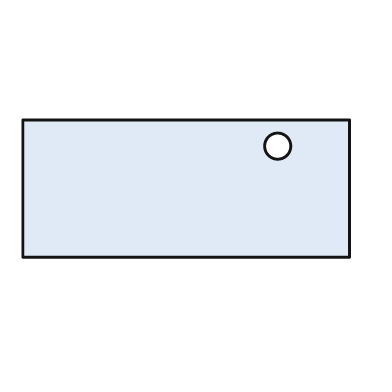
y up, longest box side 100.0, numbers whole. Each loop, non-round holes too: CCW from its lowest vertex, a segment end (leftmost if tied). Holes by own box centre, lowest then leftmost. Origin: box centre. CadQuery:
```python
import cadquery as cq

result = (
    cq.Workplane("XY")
    .moveTo(-50.0, -21.0)
    .lineTo(50.0, -21.0)
    .lineTo(50.0, 21.0)
    .lineTo(-50.0, 21.0)
    .close()
    .moveTo(28.0, 13.0)
    .circle(4.0)
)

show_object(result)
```